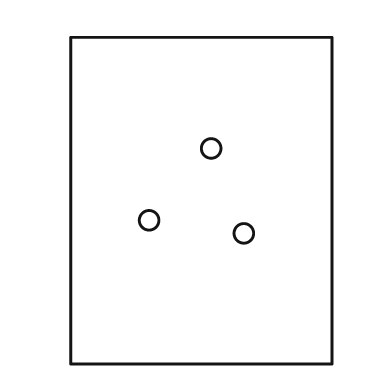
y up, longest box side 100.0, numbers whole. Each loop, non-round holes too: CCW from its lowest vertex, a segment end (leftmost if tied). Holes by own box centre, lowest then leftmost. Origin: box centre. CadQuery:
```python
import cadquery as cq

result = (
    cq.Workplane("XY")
    .moveTo(-40.0, -50.0)
    .lineTo(40.0, -50.0)
    .lineTo(40.0, 50.0)
    .lineTo(-40.0, 50.0)
    .close()
    .moveTo(13.0, -10.0)
    .circle(3.0)
    .moveTo(-16.0, -6.0)
    .circle(3.0)
    .moveTo(3.0, 16.0)
    .circle(3.0)
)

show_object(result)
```